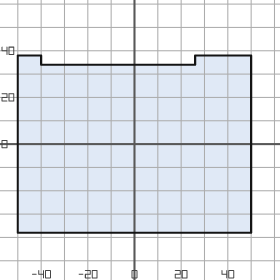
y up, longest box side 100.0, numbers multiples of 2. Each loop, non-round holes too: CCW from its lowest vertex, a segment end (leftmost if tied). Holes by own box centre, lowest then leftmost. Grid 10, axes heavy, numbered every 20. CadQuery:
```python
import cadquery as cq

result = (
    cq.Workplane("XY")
    .moveTo(-50.0, -38.0)
    .lineTo(50.0, -38.0)
    .lineTo(50.0, 38.0)
    .lineTo(26.0, 38.0)
    .lineTo(26.0, 34.0)
    .lineTo(-40.0, 34.0)
    .lineTo(-40.0, 38.0)
    .lineTo(-50.0, 38.0)
    .close()
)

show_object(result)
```